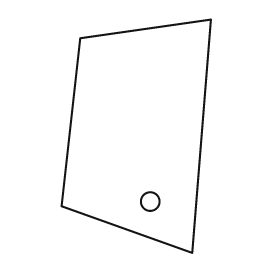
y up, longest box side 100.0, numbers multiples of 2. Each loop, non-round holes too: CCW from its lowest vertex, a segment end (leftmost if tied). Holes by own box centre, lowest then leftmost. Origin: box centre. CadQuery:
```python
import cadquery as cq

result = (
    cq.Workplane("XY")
    .moveTo(24.0, -50.0)
    .lineTo(32.0, 50.0)
    .lineTo(-24.0, 42.0)
    .lineTo(-32.0, -30.0)
    .close()
    .moveTo(6.0, -28.0)
    .circle(4.0)
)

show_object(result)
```